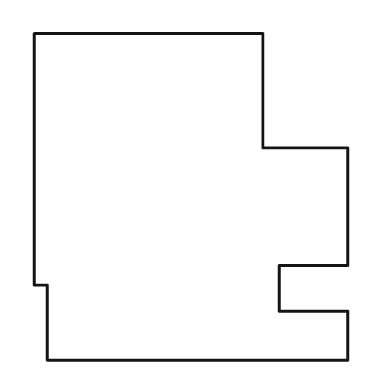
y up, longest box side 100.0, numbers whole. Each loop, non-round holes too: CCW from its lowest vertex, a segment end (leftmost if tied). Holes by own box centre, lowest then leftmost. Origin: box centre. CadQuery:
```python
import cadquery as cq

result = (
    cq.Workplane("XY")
    .moveTo(-44.0, -50.0)
    .lineTo(48.0, -50.0)
    .lineTo(48.0, -35.0)
    .lineTo(27.0, -35.0)
    .lineTo(27.0, -21.0)
    .lineTo(48.0, -21.0)
    .lineTo(48.0, 15.0)
    .lineTo(22.0, 15.0)
    .lineTo(22.0, 50.0)
    .lineTo(-48.0, 50.0)
    .lineTo(-48.0, -27.0)
    .lineTo(-44.0, -27.0)
    .close()
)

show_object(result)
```